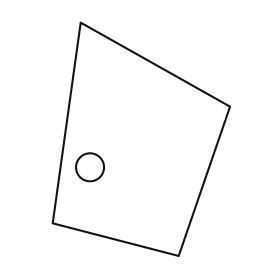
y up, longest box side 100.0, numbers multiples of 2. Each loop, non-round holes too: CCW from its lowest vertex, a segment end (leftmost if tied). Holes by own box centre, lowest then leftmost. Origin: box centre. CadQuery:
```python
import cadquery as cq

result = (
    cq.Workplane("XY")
    .moveTo(16.0, -50.0)
    .lineTo(38.0, 14.0)
    .lineTo(-26.0, 50.0)
    .lineTo(-38.0, -36.0)
    .close()
    .moveTo(-22.0, -12.0)
    .circle(6.0)
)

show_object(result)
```